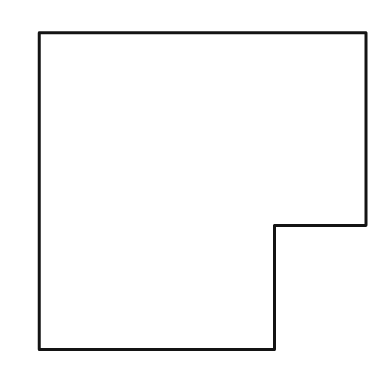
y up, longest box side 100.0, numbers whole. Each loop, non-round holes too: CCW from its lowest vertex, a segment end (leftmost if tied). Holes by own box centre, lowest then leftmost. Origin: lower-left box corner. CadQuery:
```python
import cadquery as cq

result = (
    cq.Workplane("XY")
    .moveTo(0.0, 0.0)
    .lineTo(72.0, 0.0)
    .lineTo(72.0, 38.0)
    .lineTo(100.0, 38.0)
    .lineTo(100.0, 97.0)
    .lineTo(0.0, 97.0)
    .close()
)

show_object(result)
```